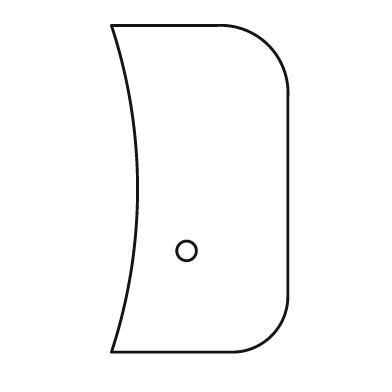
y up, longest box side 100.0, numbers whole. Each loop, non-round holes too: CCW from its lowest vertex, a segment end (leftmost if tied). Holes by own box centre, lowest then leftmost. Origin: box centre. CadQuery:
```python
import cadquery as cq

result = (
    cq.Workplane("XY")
    .moveTo(-27.0, -50.0)
    .lineTo(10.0, -50.0)
    .threePointArc((22.0, -45.0), (27.0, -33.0))
    .lineTo(27.0, 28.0)
    .threePointArc((21.0, 44.0), (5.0, 50.0))
    .lineTo(-27.0, 50.0)
    .threePointArc((-19.0, 0.0), (-27.0, -50.0))
    .close()
    .moveTo(-4.0, -19.0)
    .circle(3.0)
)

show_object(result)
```